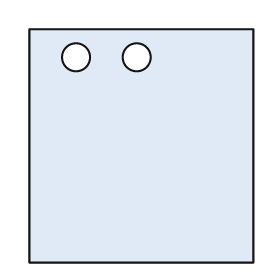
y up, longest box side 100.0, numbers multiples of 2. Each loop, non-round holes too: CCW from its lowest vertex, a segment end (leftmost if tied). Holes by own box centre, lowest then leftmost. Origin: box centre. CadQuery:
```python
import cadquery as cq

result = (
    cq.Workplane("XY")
    .moveTo(-48.0, -50.0)
    .lineTo(48.0, -50.0)
    .lineTo(48.0, 50.0)
    .lineTo(-48.0, 50.0)
    .close()
    .moveTo(-28.0, 38.0)
    .circle(6.0)
    .moveTo(-2.0, 38.0)
    .circle(6.0)
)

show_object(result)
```